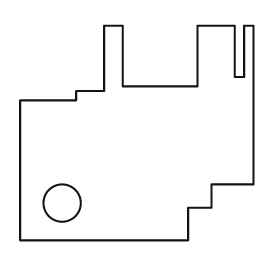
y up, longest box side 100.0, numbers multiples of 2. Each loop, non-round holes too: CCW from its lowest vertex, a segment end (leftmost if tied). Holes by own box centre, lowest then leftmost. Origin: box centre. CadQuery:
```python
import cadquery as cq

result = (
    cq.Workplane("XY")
    .moveTo(-50.0, -46.0)
    .lineTo(22.0, -46.0)
    .lineTo(22.0, -32.0)
    .lineTo(32.0, -32.0)
    .lineTo(32.0, -22.0)
    .lineTo(50.0, -22.0)
    .lineTo(50.0, 46.0)
    .lineTo(46.0, 46.0)
    .lineTo(46.0, 24.0)
    .lineTo(42.0, 24.0)
    .lineTo(42.0, 46.0)
    .lineTo(26.0, 46.0)
    .lineTo(26.0, 20.0)
    .lineTo(-6.0, 20.0)
    .lineTo(-6.0, 46.0)
    .lineTo(-14.0, 46.0)
    .lineTo(-14.0, 18.0)
    .lineTo(-26.0, 18.0)
    .lineTo(-26.0, 14.0)
    .lineTo(-50.0, 14.0)
    .close()
    .moveTo(-32.0, -30.0)
    .circle(8.0)
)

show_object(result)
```